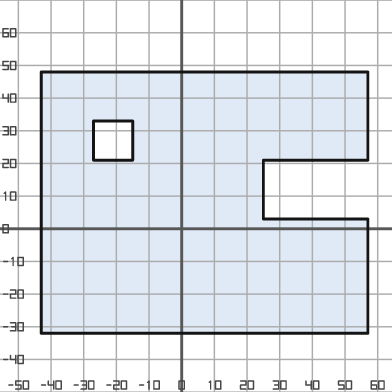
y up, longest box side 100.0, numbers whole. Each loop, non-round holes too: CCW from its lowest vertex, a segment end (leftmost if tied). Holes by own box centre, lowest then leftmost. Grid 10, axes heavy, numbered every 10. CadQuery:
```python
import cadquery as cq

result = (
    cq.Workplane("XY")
    .moveTo(-43.0, -32.0)
    .lineTo(57.0, -32.0)
    .lineTo(57.0, 3.0)
    .lineTo(25.0, 3.0)
    .lineTo(25.0, 21.0)
    .lineTo(57.0, 21.0)
    .lineTo(57.0, 48.0)
    .lineTo(-43.0, 48.0)
    .close()
    .moveTo(-27.0, 21.0)
    .lineTo(-15.0, 21.0)
    .lineTo(-15.0, 33.0)
    .lineTo(-27.0, 33.0)
    .close()
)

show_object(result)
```